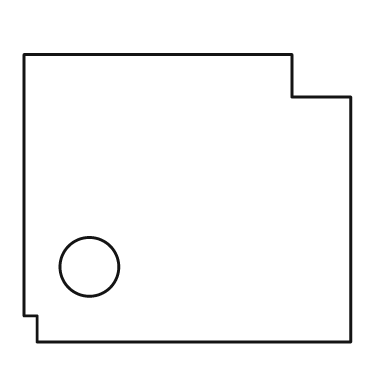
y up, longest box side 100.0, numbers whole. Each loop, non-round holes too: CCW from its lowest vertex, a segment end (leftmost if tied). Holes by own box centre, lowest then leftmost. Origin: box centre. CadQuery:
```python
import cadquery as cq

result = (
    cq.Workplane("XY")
    .moveTo(-46.0, -44.0)
    .lineTo(50.0, -44.0)
    .lineTo(50.0, 31.0)
    .lineTo(32.0, 31.0)
    .lineTo(32.0, 44.0)
    .lineTo(-50.0, 44.0)
    .lineTo(-50.0, -36.0)
    .lineTo(-46.0, -36.0)
    .close()
    .moveTo(-30.0, -21.0)
    .circle(9.0)
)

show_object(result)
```